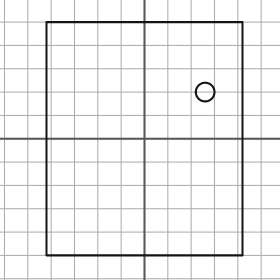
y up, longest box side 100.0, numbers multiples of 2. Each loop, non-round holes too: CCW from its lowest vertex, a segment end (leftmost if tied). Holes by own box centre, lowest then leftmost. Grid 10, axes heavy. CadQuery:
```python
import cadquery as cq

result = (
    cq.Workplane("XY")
    .moveTo(-42.0, -50.0)
    .lineTo(42.0, -50.0)
    .lineTo(42.0, 50.0)
    .lineTo(-42.0, 50.0)
    .close()
    .moveTo(26.0, 20.0)
    .circle(4.0)
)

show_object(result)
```